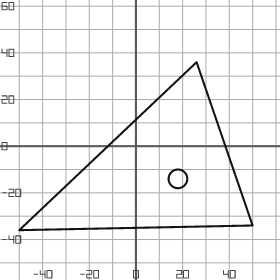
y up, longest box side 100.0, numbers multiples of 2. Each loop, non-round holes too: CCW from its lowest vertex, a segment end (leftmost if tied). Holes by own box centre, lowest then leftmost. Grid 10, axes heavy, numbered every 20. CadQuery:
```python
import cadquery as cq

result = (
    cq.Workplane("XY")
    .moveTo(-50.0, -36.0)
    .lineTo(50.0, -34.0)
    .lineTo(26.0, 36.0)
    .close()
    .moveTo(18.0, -14.0)
    .circle(4.0)
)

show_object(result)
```